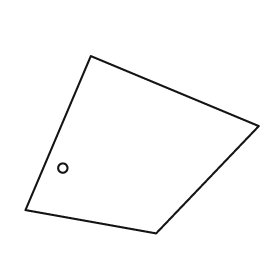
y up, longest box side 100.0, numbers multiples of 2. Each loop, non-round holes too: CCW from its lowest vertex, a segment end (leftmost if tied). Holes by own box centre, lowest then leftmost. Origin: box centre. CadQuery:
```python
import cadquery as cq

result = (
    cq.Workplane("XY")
    .moveTo(6.0, -38.0)
    .lineTo(50.0, 8.0)
    .lineTo(-22.0, 38.0)
    .lineTo(-50.0, -28.0)
    .close()
    .moveTo(-34.0, -10.0)
    .circle(2.0)
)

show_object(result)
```